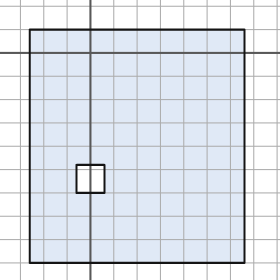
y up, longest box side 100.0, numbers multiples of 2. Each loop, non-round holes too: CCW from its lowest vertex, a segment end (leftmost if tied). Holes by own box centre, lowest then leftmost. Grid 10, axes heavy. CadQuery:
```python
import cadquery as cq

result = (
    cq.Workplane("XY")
    .moveTo(-26.0, -90.0)
    .lineTo(66.0, -90.0)
    .lineTo(66.0, 10.0)
    .lineTo(-26.0, 10.0)
    .close()
    .moveTo(-6.0, -60.0)
    .lineTo(6.0, -60.0)
    .lineTo(6.0, -48.0)
    .lineTo(-6.0, -48.0)
    .close()
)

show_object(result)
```